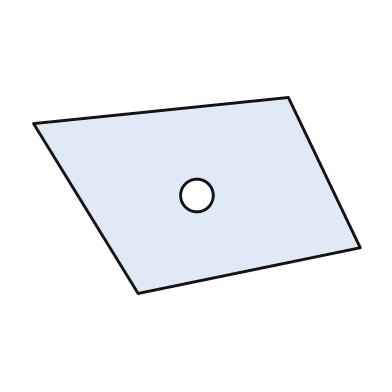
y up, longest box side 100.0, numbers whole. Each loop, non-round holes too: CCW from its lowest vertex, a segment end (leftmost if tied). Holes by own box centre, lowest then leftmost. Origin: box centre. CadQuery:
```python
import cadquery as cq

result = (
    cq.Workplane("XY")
    .moveTo(-18.0, -30.0)
    .lineTo(50.0, -16.0)
    .lineTo(28.0, 30.0)
    .lineTo(-50.0, 22.0)
    .close()
    .moveTo(0.0, 0.0)
    .circle(5.0)
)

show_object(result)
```